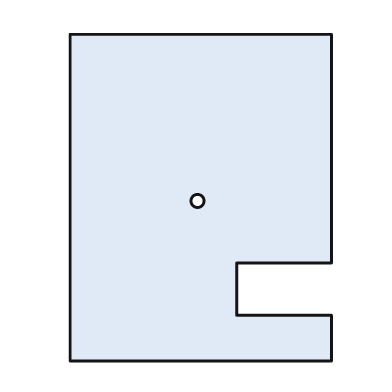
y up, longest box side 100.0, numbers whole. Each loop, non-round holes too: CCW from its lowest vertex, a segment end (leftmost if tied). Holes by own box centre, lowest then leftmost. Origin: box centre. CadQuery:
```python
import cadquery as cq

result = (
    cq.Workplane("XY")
    .moveTo(-40.0, -50.0)
    .lineTo(40.0, -50.0)
    .lineTo(40.0, -36.0)
    .lineTo(11.0, -36.0)
    .lineTo(11.0, -20.0)
    .lineTo(40.0, -20.0)
    .lineTo(40.0, 50.0)
    .lineTo(-40.0, 50.0)
    .close()
    .moveTo(-1.0, -1.0)
    .circle(2.0)
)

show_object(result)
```